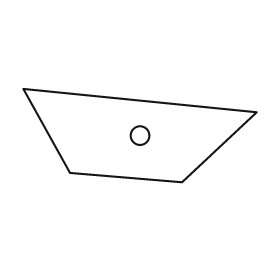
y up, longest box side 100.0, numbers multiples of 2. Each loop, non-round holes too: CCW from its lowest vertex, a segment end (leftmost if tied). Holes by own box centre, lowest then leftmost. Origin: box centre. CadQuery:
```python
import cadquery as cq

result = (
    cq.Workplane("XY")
    .moveTo(18.0, -20.0)
    .lineTo(50.0, 10.0)
    .lineTo(-50.0, 20.0)
    .lineTo(-30.0, -16.0)
    .close()
    .moveTo(0.0, 0.0)
    .circle(4.0)
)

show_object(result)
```